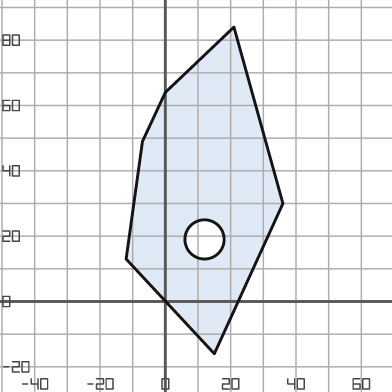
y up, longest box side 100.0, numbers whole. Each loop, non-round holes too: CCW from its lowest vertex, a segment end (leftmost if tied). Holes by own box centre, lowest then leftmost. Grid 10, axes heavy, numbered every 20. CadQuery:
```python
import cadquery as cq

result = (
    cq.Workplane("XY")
    .moveTo(15.0, -16.0)
    .lineTo(36.0, 30.0)
    .lineTo(21.0, 84.0)
    .lineTo(0.0, 64.0)
    .lineTo(-7.0, 49.0)
    .lineTo(-12.0, 13.0)
    .close()
    .moveTo(12.0, 19.0)
    .circle(6.0)
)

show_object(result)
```